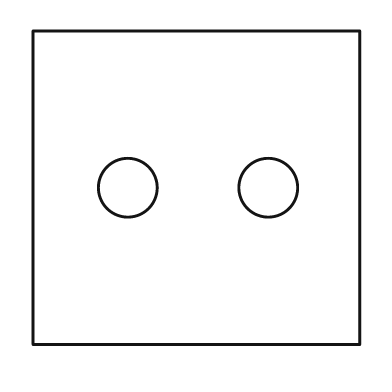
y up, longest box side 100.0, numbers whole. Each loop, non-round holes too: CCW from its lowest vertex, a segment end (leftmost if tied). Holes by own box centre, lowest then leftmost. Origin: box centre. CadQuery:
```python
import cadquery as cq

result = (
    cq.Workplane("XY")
    .moveTo(-50.0, -48.0)
    .lineTo(50.0, -48.0)
    .lineTo(50.0, 48.0)
    .lineTo(-50.0, 48.0)
    .close()
    .moveTo(-21.0, 0.0)
    .circle(9.0)
    .moveTo(22.0, 0.0)
    .circle(9.0)
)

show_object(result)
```